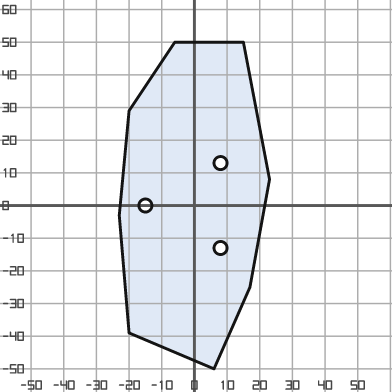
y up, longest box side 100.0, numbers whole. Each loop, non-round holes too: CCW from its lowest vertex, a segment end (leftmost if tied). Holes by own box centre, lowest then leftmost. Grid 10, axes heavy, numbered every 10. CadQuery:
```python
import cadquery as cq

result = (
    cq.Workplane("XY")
    .moveTo(6.0, -50.0)
    .lineTo(17.0, -25.0)
    .lineTo(23.0, 8.0)
    .lineTo(15.0, 50.0)
    .lineTo(-6.0, 50.0)
    .lineTo(-20.0, 29.0)
    .lineTo(-23.0, -3.0)
    .lineTo(-20.0, -39.0)
    .close()
    .moveTo(8.0, -13.0)
    .circle(2.0)
    .moveTo(-15.0, 0.0)
    .circle(2.0)
    .moveTo(8.0, 13.0)
    .circle(2.0)
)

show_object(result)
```